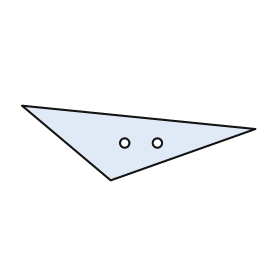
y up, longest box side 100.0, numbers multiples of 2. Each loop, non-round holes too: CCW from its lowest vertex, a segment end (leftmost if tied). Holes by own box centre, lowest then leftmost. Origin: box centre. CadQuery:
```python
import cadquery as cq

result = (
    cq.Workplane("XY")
    .moveTo(-12.0, -16.0)
    .lineTo(50.0, 6.0)
    .lineTo(-50.0, 16.0)
    .close()
    .moveTo(-6.0, 0.0)
    .circle(2.0)
    .moveTo(8.0, 0.0)
    .circle(2.0)
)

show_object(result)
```